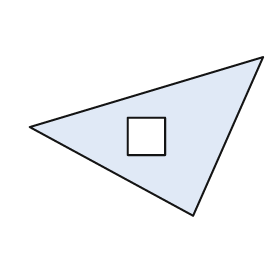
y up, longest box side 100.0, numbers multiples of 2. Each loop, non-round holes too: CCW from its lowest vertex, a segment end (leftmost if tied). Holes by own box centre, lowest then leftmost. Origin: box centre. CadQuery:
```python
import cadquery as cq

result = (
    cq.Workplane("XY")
    .moveTo(20.0, -34.0)
    .lineTo(50.0, 34.0)
    .lineTo(-50.0, 4.0)
    .close()
    .moveTo(-8.0, -8.0)
    .lineTo(8.0, -8.0)
    .lineTo(8.0, 8.0)
    .lineTo(-8.0, 8.0)
    .close()
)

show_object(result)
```